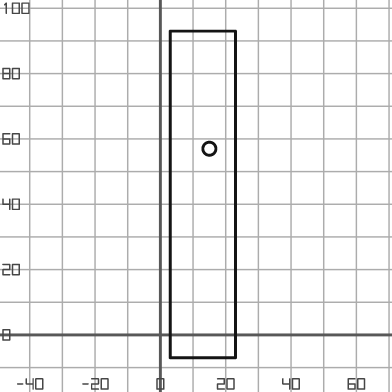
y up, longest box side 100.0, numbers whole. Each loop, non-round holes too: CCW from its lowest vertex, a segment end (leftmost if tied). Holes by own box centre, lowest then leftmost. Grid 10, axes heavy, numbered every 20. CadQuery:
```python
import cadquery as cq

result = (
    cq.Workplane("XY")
    .moveTo(3.0, -7.0)
    .lineTo(23.0, -7.0)
    .lineTo(23.0, 93.0)
    .lineTo(3.0, 93.0)
    .close()
    .moveTo(15.0, 57.0)
    .circle(2.0)
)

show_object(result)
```